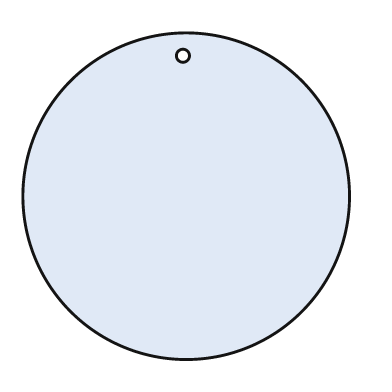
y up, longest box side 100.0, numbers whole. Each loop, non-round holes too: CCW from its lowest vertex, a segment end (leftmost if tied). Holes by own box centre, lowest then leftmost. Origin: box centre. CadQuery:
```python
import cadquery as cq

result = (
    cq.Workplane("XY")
    .moveTo(0.0, 0.0)
    .circle(50.0)
    .moveTo(-1.0, 43.0)
    .circle(2.0)
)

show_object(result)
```